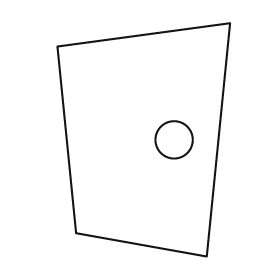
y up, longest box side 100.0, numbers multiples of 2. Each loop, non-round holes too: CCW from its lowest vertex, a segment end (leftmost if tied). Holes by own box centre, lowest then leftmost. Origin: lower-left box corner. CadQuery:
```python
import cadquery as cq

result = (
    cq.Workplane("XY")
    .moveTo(64.0, 0.0)
    .lineTo(74.0, 100.0)
    .lineTo(0.0, 90.0)
    .lineTo(8.0, 10.0)
    .close()
    .moveTo(50.0, 50.0)
    .circle(8.0)
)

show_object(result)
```